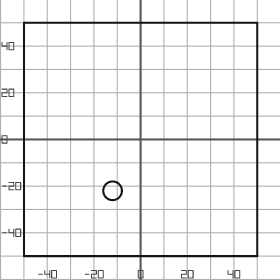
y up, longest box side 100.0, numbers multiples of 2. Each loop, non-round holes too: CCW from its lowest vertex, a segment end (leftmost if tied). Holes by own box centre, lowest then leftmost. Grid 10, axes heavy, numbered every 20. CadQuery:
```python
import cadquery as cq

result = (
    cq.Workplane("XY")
    .moveTo(-50.0, -50.0)
    .lineTo(50.0, -50.0)
    .lineTo(50.0, 50.0)
    .lineTo(-50.0, 50.0)
    .close()
    .moveTo(-12.0, -22.0)
    .circle(4.0)
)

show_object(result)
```